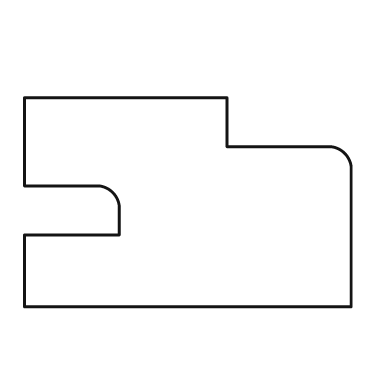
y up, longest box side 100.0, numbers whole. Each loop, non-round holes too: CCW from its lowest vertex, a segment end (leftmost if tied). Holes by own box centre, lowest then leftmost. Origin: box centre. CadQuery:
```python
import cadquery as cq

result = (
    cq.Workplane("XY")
    .moveTo(-50.0, -32.0)
    .lineTo(50.0, -32.0)
    .lineTo(50.0, 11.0)
    .threePointArc((48.0, 15.0), (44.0, 17.0))
    .lineTo(12.0, 17.0)
    .lineTo(12.0, 32.0)
    .lineTo(-50.0, 32.0)
    .lineTo(-50.0, 5.0)
    .lineTo(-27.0, 5.0)
    .threePointArc((-23.0, 3.0), (-21.0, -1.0))
    .lineTo(-21.0, -10.0)
    .lineTo(-50.0, -10.0)
    .close()
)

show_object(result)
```